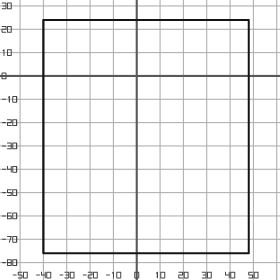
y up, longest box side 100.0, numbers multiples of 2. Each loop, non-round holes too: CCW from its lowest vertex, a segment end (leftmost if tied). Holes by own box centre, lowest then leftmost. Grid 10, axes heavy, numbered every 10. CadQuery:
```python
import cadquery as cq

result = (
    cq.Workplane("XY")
    .moveTo(-40.0, -76.0)
    .lineTo(48.0, -76.0)
    .lineTo(48.0, 24.0)
    .lineTo(-40.0, 24.0)
    .close()
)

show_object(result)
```